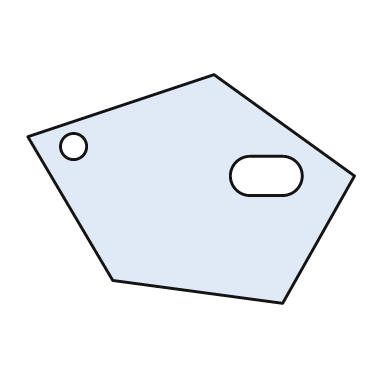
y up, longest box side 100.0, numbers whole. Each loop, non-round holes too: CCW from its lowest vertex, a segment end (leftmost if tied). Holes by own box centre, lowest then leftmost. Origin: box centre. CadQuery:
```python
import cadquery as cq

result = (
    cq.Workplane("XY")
    .moveTo(28.0, -35.0)
    .lineTo(50.0, 4.0)
    .lineTo(7.0, 35.0)
    .lineTo(-50.0, 16.0)
    .lineTo(-24.0, -28.0)
    .close()
    .moveTo(18.0, -2.0)
    .lineTo(28.0, -2.0)
    .threePointArc((34.0, 4.0), (28.0, 10.0))
    .lineTo(18.0, 10.0)
    .threePointArc((12.0, 4.0), (18.0, -2.0))
    .close()
    .moveTo(-36.0, 13.0)
    .circle(4.0)
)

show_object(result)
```